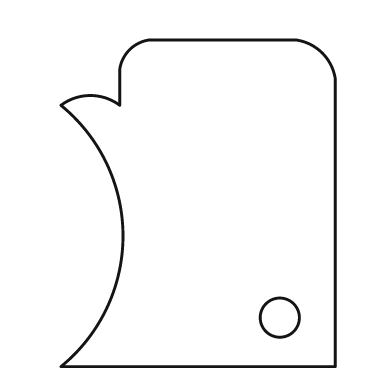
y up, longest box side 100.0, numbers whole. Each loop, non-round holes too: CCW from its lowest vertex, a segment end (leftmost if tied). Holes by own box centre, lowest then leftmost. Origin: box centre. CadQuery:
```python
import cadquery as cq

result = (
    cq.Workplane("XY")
    .moveTo(-42.0, -50.0)
    .lineTo(42.0, -50.0)
    .lineTo(42.0, 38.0)
    .threePointArc((38.0, 46.0), (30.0, 50.0))
    .lineTo(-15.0, 50.0)
    .threePointArc((-21.0, 47.0), (-24.0, 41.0))
    .lineTo(-24.0, 30.0)
    .threePointArc((-33.0, 33.0), (-42.0, 30.0))
    .threePointArc((-23.0, -10.0), (-42.0, -50.0))
    .close()
    .moveTo(25.0, -35.0)
    .circle(6.0)
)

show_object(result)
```